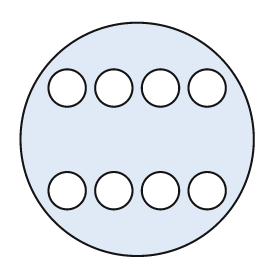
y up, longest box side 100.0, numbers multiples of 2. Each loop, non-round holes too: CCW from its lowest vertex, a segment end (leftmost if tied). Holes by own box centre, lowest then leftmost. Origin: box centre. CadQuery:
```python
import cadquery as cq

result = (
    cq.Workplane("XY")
    .moveTo(0.0, 0.0)
    .circle(50.0)
    .moveTo(-30.0, -22.0)
    .circle(8.0)
    .moveTo(-10.0, -22.0)
    .circle(8.0)
    .moveTo(10.0, -22.0)
    .circle(8.0)
    .moveTo(30.0, -22.0)
    .circle(8.0)
    .moveTo(-30.0, 22.0)
    .circle(8.0)
    .moveTo(-10.0, 22.0)
    .circle(8.0)
    .moveTo(10.0, 22.0)
    .circle(8.0)
    .moveTo(30.0, 22.0)
    .circle(8.0)
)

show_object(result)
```